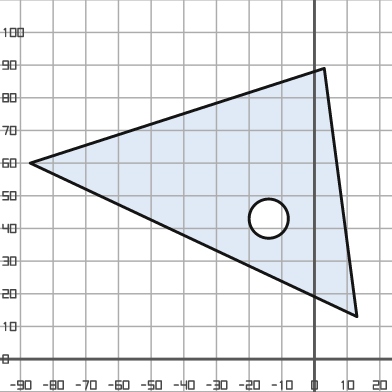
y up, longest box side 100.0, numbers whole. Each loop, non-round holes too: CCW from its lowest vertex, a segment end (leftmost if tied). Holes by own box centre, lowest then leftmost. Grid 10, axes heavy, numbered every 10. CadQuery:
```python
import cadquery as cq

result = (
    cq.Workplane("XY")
    .moveTo(13.0, 13.0)
    .lineTo(3.0, 89.0)
    .lineTo(-87.0, 60.0)
    .close()
    .moveTo(-14.0, 43.0)
    .circle(6.0)
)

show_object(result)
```